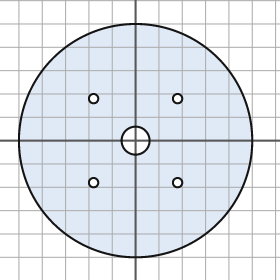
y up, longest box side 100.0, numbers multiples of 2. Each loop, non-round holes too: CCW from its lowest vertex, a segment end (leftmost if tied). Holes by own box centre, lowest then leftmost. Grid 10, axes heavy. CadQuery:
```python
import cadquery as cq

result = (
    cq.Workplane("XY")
    .moveTo(0.0, 0.0)
    .circle(50.0)
    .moveTo(-18.0, -18.0)
    .circle(2.0)
    .moveTo(18.0, -18.0)
    .circle(2.0)
    .moveTo(0.0, 0.0)
    .circle(6.0)
    .moveTo(-18.0, 18.0)
    .circle(2.0)
    .moveTo(18.0, 18.0)
    .circle(2.0)
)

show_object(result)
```